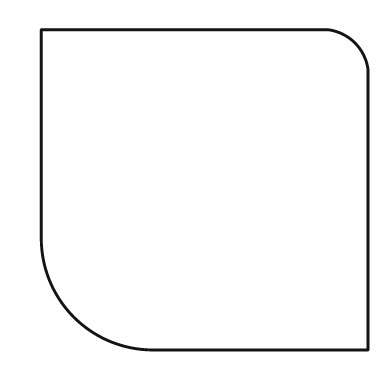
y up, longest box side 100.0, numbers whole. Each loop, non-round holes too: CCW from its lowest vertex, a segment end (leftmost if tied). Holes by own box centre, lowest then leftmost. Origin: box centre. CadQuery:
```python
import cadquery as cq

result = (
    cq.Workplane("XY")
    .moveTo(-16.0, -49.0)
    .lineTo(50.0, -49.0)
    .lineTo(50.0, 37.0)
    .threePointArc((46.0, 45.0), (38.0, 49.0))
    .lineTo(-50.0, 49.0)
    .lineTo(-50.0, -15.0)
    .threePointArc((-40.0, -39.0), (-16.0, -49.0))
    .close()
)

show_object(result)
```